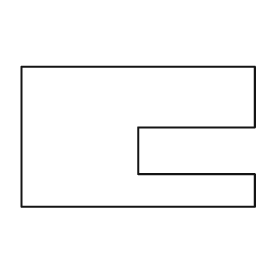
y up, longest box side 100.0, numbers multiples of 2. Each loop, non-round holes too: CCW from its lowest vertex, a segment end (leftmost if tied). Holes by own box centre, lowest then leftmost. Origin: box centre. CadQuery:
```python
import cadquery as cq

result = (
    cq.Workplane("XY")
    .moveTo(-50.0, -30.0)
    .lineTo(50.0, -30.0)
    .lineTo(50.0, -16.0)
    .lineTo(0.0, -16.0)
    .lineTo(0.0, 4.0)
    .lineTo(50.0, 4.0)
    .lineTo(50.0, 30.0)
    .lineTo(-50.0, 30.0)
    .close()
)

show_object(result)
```